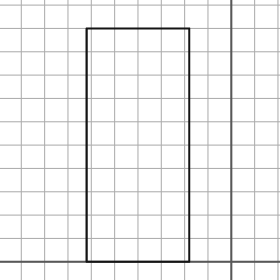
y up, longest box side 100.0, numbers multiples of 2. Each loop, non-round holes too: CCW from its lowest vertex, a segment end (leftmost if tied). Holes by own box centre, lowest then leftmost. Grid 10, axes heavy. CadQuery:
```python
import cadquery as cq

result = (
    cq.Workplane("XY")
    .moveTo(-62.0, 0.0)
    .lineTo(-18.0, 0.0)
    .lineTo(-18.0, 100.0)
    .lineTo(-62.0, 100.0)
    .close()
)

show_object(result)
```